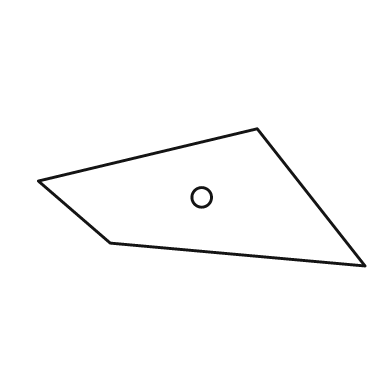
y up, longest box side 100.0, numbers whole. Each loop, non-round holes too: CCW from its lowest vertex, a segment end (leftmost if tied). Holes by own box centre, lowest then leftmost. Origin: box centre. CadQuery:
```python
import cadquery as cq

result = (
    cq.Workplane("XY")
    .moveTo(50.0, -21.0)
    .lineTo(17.0, 21.0)
    .lineTo(-50.0, 5.0)
    .lineTo(-28.0, -14.0)
    .close()
    .moveTo(0.0, 0.0)
    .circle(3.0)
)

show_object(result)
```